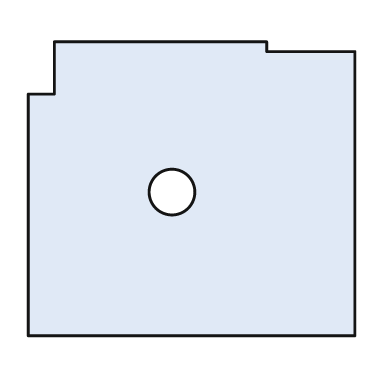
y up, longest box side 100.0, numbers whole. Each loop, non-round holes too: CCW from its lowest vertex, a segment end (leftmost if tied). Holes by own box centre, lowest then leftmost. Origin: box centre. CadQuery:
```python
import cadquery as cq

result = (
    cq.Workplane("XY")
    .moveTo(-50.0, -45.0)
    .lineTo(50.0, -45.0)
    .lineTo(50.0, 42.0)
    .lineTo(23.0, 42.0)
    .lineTo(23.0, 45.0)
    .lineTo(-42.0, 45.0)
    .lineTo(-42.0, 29.0)
    .lineTo(-50.0, 29.0)
    .close()
    .moveTo(-6.0, -1.0)
    .circle(7.0)
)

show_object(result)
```